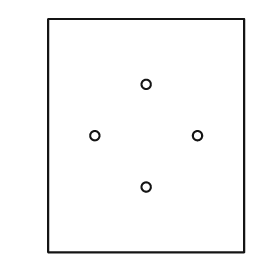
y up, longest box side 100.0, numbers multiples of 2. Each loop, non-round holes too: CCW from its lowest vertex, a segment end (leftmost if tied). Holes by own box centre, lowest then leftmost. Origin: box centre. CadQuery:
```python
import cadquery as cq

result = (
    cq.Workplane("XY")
    .moveTo(-42.0, -50.0)
    .lineTo(42.0, -50.0)
    .lineTo(42.0, 50.0)
    .lineTo(-42.0, 50.0)
    .close()
    .moveTo(0.0, -22.0)
    .circle(2.0)
    .moveTo(-22.0, 0.0)
    .circle(2.0)
    .moveTo(22.0, 0.0)
    .circle(2.0)
    .moveTo(0.0, 22.0)
    .circle(2.0)
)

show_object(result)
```